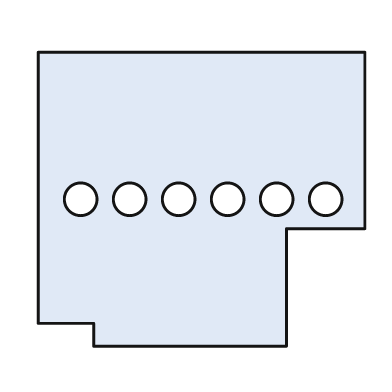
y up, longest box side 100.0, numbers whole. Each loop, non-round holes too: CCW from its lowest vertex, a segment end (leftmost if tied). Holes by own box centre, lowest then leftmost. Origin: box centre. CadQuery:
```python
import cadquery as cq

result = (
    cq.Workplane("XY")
    .moveTo(-33.0, -45.0)
    .lineTo(26.0, -45.0)
    .lineTo(26.0, -9.0)
    .lineTo(50.0, -9.0)
    .lineTo(50.0, 45.0)
    .lineTo(-50.0, 45.0)
    .lineTo(-50.0, -38.0)
    .lineTo(-33.0, -38.0)
    .close()
    .moveTo(-37.0, 0.0)
    .circle(5.0)
    .moveTo(-22.0, 0.0)
    .circle(5.0)
    .moveTo(-7.0, 0.0)
    .circle(5.0)
    .moveTo(8.0, 0.0)
    .circle(5.0)
    .moveTo(23.0, 0.0)
    .circle(5.0)
    .moveTo(38.0, 0.0)
    .circle(5.0)
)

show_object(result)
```